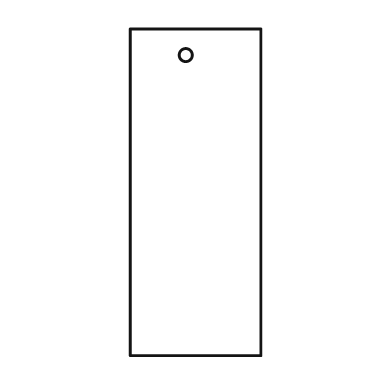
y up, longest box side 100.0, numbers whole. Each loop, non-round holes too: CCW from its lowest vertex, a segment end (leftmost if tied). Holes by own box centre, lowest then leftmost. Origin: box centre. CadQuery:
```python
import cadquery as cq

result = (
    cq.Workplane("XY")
    .moveTo(-20.0, -50.0)
    .lineTo(20.0, -50.0)
    .lineTo(20.0, 50.0)
    .lineTo(-20.0, 50.0)
    .close()
    .moveTo(-3.0, 42.0)
    .circle(2.0)
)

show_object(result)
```